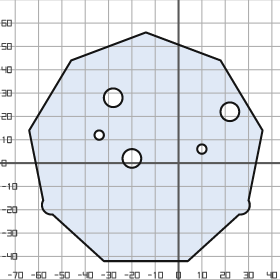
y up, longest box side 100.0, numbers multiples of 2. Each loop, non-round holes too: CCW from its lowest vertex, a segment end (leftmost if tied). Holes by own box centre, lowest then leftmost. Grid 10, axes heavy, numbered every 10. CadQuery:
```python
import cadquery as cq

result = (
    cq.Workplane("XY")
    .moveTo(-32.0, -42.0)
    .lineTo(4.0, -42.0)
    .lineTo(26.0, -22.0)
    .threePointArc((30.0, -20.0), (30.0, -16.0))
    .lineTo(36.0, 14.0)
    .lineTo(18.0, 44.0)
    .lineTo(-14.0, 56.0)
    .lineTo(-46.0, 44.0)
    .lineTo(-64.0, 14.0)
    .lineTo(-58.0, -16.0)
    .threePointArc((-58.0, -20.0), (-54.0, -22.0))
    .close()
    .moveTo(-20.0, 2.0)
    .circle(4.0)
    .moveTo(10.0, 6.0)
    .circle(2.0)
    .moveTo(-34.0, 12.0)
    .circle(2.0)
    .moveTo(22.0, 22.0)
    .circle(4.0)
    .moveTo(-28.0, 28.0)
    .circle(4.0)
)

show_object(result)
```